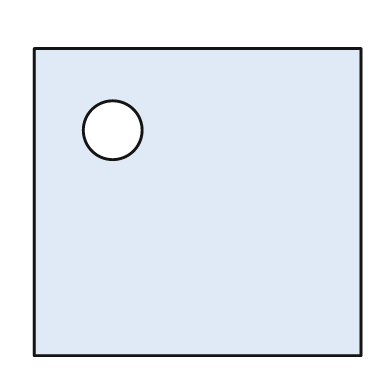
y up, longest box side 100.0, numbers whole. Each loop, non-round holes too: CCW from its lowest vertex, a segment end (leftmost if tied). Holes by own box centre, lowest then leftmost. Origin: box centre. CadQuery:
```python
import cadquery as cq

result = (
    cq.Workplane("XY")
    .moveTo(-50.0, -47.0)
    .lineTo(50.0, -47.0)
    .lineTo(50.0, 47.0)
    .lineTo(-50.0, 47.0)
    .close()
    .moveTo(-26.0, 22.0)
    .circle(9.0)
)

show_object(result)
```